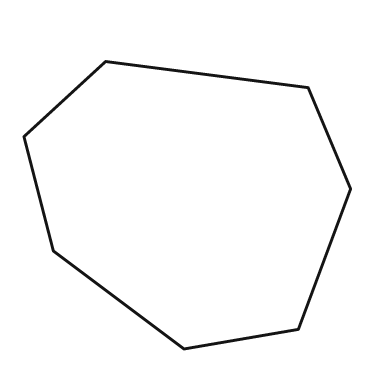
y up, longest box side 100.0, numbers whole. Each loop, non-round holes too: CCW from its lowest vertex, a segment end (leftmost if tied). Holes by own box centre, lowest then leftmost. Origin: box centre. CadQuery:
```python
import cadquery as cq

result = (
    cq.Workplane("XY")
    .moveTo(-1.0, -44.0)
    .lineTo(34.0, -38.0)
    .lineTo(50.0, 5.0)
    .lineTo(37.0, 36.0)
    .lineTo(-25.0, 44.0)
    .lineTo(-50.0, 21.0)
    .lineTo(-41.0, -14.0)
    .close()
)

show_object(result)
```